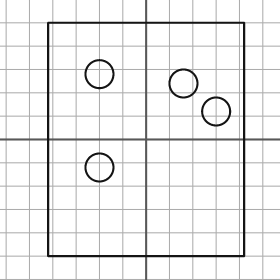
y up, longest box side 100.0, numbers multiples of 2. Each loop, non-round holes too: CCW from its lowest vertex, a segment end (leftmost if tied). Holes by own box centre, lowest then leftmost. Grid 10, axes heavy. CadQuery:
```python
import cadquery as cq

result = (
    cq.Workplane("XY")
    .moveTo(-42.0, -50.0)
    .lineTo(42.0, -50.0)
    .lineTo(42.0, 50.0)
    .lineTo(-42.0, 50.0)
    .close()
    .moveTo(-20.0, -12.0)
    .circle(6.0)
    .moveTo(30.0, 12.0)
    .circle(6.0)
    .moveTo(16.0, 24.0)
    .circle(6.0)
    .moveTo(-20.0, 28.0)
    .circle(6.0)
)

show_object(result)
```